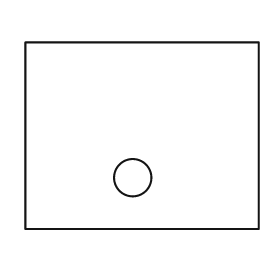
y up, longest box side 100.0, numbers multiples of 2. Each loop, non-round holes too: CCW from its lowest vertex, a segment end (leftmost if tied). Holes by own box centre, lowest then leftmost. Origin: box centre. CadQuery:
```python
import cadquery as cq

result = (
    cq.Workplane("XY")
    .moveTo(-50.0, -40.0)
    .lineTo(50.0, -40.0)
    .lineTo(50.0, 40.0)
    .lineTo(-50.0, 40.0)
    .close()
    .moveTo(-4.0, -18.0)
    .circle(8.0)
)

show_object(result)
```